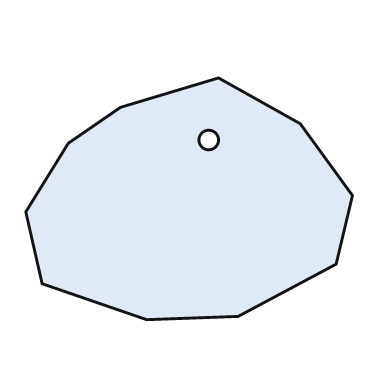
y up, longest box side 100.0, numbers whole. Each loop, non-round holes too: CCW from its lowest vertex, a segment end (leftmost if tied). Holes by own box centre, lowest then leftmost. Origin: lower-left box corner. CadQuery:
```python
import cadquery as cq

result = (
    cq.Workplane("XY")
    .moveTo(37.0, 0.0)
    .lineTo(65.0, 1.0)
    .lineTo(95.0, 17.0)
    .lineTo(100.0, 38.0)
    .lineTo(84.0, 60.0)
    .lineTo(59.0, 74.0)
    .lineTo(29.0, 65.0)
    .lineTo(13.0, 54.0)
    .lineTo(0.0, 33.0)
    .lineTo(5.0, 11.0)
    .close()
    .moveTo(56.0, 55.0)
    .circle(3.0)
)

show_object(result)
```